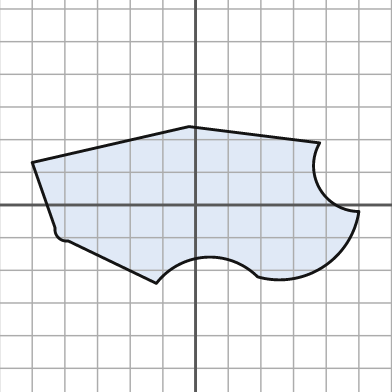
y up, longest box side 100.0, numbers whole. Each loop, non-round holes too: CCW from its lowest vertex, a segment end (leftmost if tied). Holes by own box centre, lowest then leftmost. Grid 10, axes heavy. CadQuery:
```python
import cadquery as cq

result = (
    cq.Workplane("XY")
    .moveTo(-12.0, -24.0)
    .threePointArc((3.0, -16.0), (19.0, -22.0))
    .threePointArc((39.0, -19.0), (50.0, -2.0))
    .threePointArc((38.0, 5.0), (38.0, 19.0))
    .lineTo(-2.0, 24.0)
    .lineTo(-50.0, 13.0)
    .lineTo(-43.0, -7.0)
    .threePointArc((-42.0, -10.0), (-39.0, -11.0))
    .close()
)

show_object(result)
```